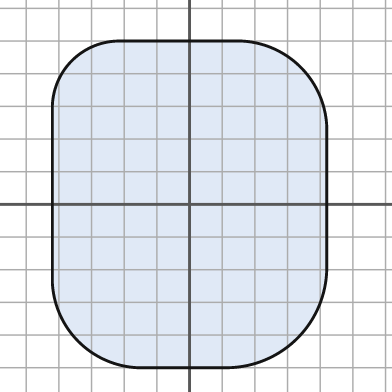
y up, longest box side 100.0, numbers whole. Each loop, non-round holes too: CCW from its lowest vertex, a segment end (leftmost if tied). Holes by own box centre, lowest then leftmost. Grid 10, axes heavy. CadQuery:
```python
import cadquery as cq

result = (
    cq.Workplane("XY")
    .moveTo(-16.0, -50.0)
    .lineTo(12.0, -50.0)
    .threePointArc((33.0, -41.0), (42.0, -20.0))
    .lineTo(42.0, 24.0)
    .threePointArc((34.0, 42.0), (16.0, 50.0))
    .lineTo(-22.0, 50.0)
    .threePointArc((-36.0, 44.0), (-42.0, 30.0))
    .lineTo(-42.0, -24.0)
    .threePointArc((-34.0, -42.0), (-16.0, -50.0))
    .close()
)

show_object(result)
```